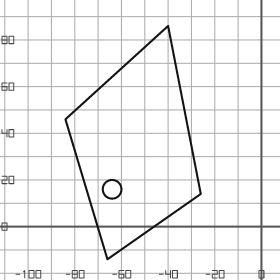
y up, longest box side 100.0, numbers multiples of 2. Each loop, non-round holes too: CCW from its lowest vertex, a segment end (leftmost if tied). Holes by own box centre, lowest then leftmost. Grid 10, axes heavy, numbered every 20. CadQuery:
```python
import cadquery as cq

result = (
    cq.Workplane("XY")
    .moveTo(-66.0, -14.0)
    .lineTo(-26.0, 14.0)
    .lineTo(-40.0, 86.0)
    .lineTo(-84.0, 46.0)
    .close()
    .moveTo(-64.0, 16.0)
    .circle(4.0)
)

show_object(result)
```